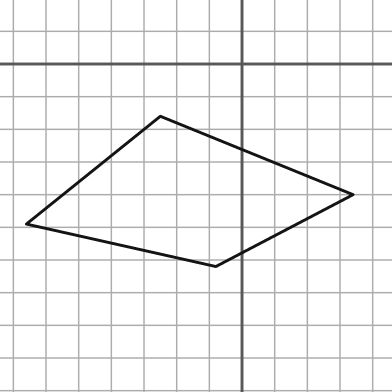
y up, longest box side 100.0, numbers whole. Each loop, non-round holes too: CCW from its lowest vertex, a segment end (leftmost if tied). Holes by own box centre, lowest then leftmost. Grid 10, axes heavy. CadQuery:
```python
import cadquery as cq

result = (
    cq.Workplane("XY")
    .moveTo(-8.0, -62.0)
    .lineTo(34.0, -40.0)
    .lineTo(-25.0, -16.0)
    .lineTo(-66.0, -49.0)
    .close()
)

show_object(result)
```